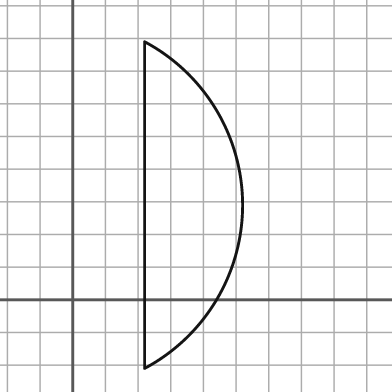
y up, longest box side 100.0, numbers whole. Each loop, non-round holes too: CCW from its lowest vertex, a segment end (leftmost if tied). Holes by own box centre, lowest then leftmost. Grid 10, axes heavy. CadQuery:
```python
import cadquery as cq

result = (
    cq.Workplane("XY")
    .moveTo(22.0, -21.0)
    .threePointArc((52.0, 29.0), (22.0, 79.0))
    .close()
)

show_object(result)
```